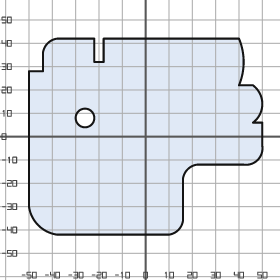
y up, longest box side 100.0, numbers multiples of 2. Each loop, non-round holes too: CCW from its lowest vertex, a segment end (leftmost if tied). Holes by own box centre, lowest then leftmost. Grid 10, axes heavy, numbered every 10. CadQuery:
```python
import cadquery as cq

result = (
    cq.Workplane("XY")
    .moveTo(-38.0, -42.0)
    .lineTo(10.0, -42.0)
    .threePointArc((14.0, -40.0), (16.0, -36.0))
    .lineTo(16.0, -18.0)
    .threePointArc((18.0, -14.0), (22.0, -12.0))
    .lineTo(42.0, -12.0)
    .threePointArc((48.0, -10.0), (50.0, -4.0))
    .lineTo(50.0, 6.0)
    .lineTo(46.0, 6.0)
    .threePointArc((50.0, 14.0), (46.0, 22.0))
    .lineTo(40.0, 22.0)
    .threePointArc((42.0, 32.0), (40.0, 42.0))
    .lineTo(-18.0, 42.0)
    .lineTo(-18.0, 32.0)
    .lineTo(-22.0, 32.0)
    .lineTo(-22.0, 42.0)
    .lineTo(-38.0, 42.0)
    .threePointArc((-42.0, 40.0), (-44.0, 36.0))
    .lineTo(-44.0, 28.0)
    .lineTo(-50.0, 28.0)
    .lineTo(-50.0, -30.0)
    .threePointArc((-46.0, -38.0), (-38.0, -42.0))
    .close()
    .moveTo(-26.0, 8.0)
    .circle(4.0)
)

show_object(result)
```